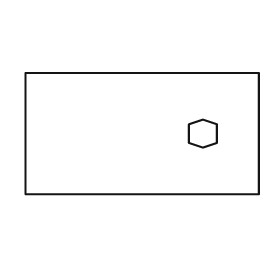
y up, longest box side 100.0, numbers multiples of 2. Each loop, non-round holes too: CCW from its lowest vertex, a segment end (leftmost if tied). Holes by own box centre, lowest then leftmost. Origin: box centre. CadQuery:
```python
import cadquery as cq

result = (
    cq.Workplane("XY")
    .moveTo(-50.0, -26.0)
    .lineTo(50.0, -26.0)
    .lineTo(50.0, 26.0)
    .lineTo(-50.0, 26.0)
    .close()
    .moveTo(26.0, -6.0)
    .lineTo(32.0, -4.0)
    .lineTo(32.0, 4.0)
    .lineTo(26.0, 6.0)
    .lineTo(20.0, 4.0)
    .lineTo(20.0, -4.0)
    .close()
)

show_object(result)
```